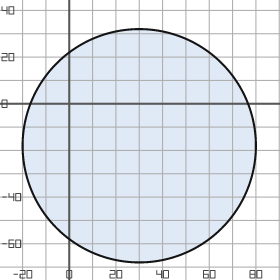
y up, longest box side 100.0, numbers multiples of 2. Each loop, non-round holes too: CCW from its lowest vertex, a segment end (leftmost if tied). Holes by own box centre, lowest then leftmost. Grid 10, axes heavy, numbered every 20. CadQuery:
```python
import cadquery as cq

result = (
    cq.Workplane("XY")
    .moveTo(30.0, -18.0)
    .circle(50.0)
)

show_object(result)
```